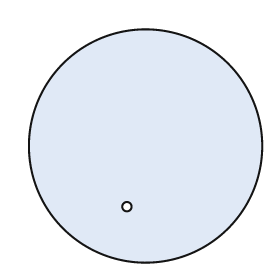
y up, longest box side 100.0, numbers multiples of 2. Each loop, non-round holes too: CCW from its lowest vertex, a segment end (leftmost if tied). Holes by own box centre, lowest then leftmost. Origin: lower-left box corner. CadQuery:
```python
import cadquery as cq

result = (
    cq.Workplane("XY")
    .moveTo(50.0, 50.0)
    .circle(50.0)
    .moveTo(42.0, 24.0)
    .circle(2.0)
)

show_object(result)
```